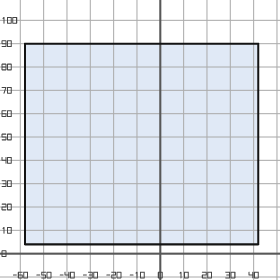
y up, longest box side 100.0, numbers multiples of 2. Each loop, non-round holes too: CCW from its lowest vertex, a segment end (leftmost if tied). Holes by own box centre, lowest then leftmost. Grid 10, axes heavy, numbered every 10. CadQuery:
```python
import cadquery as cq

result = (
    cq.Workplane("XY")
    .moveTo(-58.0, 4.0)
    .lineTo(42.0, 4.0)
    .lineTo(42.0, 90.0)
    .lineTo(-58.0, 90.0)
    .close()
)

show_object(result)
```